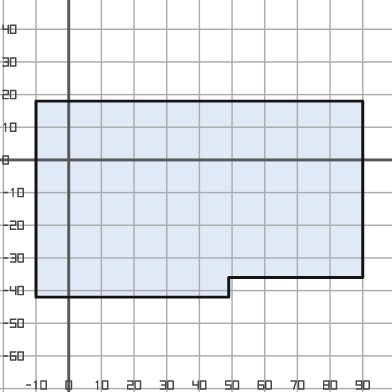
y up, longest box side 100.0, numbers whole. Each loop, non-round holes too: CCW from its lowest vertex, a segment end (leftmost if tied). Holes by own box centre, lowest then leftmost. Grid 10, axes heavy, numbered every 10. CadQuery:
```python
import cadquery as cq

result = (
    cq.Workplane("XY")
    .moveTo(-10.0, -42.0)
    .lineTo(49.0, -42.0)
    .lineTo(49.0, -36.0)
    .lineTo(90.0, -36.0)
    .lineTo(90.0, 18.0)
    .lineTo(-10.0, 18.0)
    .close()
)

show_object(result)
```